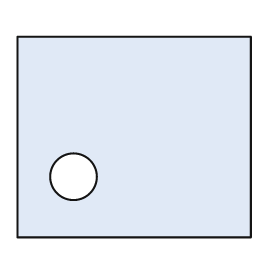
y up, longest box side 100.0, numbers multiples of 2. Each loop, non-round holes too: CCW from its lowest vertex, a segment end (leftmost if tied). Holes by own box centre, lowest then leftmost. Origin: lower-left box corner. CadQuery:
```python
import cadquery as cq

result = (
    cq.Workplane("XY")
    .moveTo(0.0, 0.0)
    .lineTo(100.0, 0.0)
    .lineTo(100.0, 86.0)
    .lineTo(0.0, 86.0)
    .close()
    .moveTo(24.0, 26.0)
    .circle(10.0)
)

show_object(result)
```